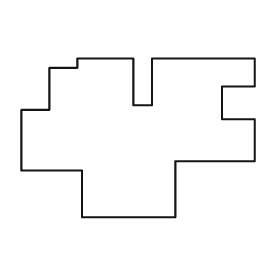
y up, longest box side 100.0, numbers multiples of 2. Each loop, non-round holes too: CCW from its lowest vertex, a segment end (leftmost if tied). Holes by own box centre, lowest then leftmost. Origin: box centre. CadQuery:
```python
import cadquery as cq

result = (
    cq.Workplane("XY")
    .moveTo(-24.0, -34.0)
    .lineTo(16.0, -34.0)
    .lineTo(16.0, -10.0)
    .lineTo(50.0, -10.0)
    .lineTo(50.0, 8.0)
    .lineTo(36.0, 8.0)
    .lineTo(36.0, 22.0)
    .lineTo(50.0, 22.0)
    .lineTo(50.0, 34.0)
    .lineTo(6.0, 34.0)
    .lineTo(6.0, 14.0)
    .lineTo(-2.0, 14.0)
    .lineTo(-2.0, 34.0)
    .lineTo(-26.0, 34.0)
    .lineTo(-26.0, 30.0)
    .lineTo(-38.0, 30.0)
    .lineTo(-38.0, 12.0)
    .lineTo(-50.0, 12.0)
    .lineTo(-50.0, -14.0)
    .lineTo(-24.0, -14.0)
    .close()
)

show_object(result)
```